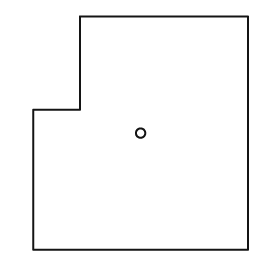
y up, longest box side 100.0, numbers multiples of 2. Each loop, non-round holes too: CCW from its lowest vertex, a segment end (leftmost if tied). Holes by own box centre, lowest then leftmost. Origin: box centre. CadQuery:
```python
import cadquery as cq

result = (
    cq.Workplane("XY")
    .moveTo(-46.0, -50.0)
    .lineTo(46.0, -50.0)
    .lineTo(46.0, 50.0)
    .lineTo(-26.0, 50.0)
    .lineTo(-26.0, 10.0)
    .lineTo(-46.0, 10.0)
    .close()
    .moveTo(0.0, 0.0)
    .circle(2.0)
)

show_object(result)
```